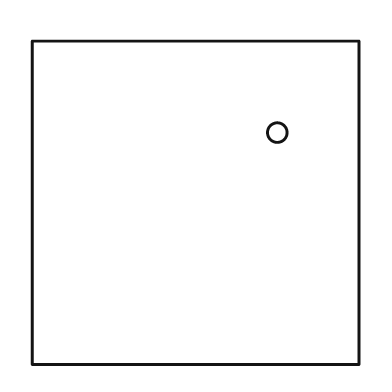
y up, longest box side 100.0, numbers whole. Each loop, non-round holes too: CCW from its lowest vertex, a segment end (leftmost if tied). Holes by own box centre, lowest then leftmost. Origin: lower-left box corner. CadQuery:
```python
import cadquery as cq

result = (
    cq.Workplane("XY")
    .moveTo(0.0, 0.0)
    .lineTo(100.0, 0.0)
    .lineTo(100.0, 99.0)
    .lineTo(0.0, 99.0)
    .close()
    .moveTo(75.0, 71.0)
    .circle(3.0)
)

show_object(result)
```